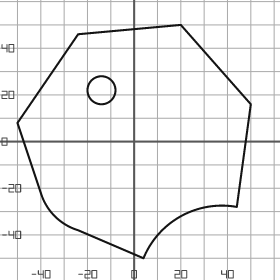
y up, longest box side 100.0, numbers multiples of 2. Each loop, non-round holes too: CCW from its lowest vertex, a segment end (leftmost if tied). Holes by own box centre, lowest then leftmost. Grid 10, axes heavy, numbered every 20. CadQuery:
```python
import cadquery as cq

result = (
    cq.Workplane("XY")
    .moveTo(4.0, -50.0)
    .threePointArc((20.0, -32.0), (44.0, -28.0))
    .lineTo(50.0, 16.0)
    .lineTo(20.0, 50.0)
    .lineTo(-24.0, 46.0)
    .lineTo(-50.0, 8.0)
    .lineTo(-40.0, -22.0)
    .threePointArc((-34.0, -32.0), (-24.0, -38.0))
    .close()
    .moveTo(-14.0, 22.0)
    .circle(6.0)
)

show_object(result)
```